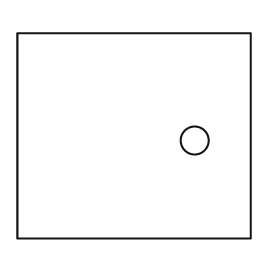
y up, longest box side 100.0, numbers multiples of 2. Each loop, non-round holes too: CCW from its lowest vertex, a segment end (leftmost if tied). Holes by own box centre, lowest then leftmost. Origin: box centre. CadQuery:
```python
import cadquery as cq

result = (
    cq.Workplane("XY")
    .moveTo(-50.0, -44.0)
    .lineTo(50.0, -44.0)
    .lineTo(50.0, 44.0)
    .lineTo(-50.0, 44.0)
    .close()
    .moveTo(26.0, -2.0)
    .circle(6.0)
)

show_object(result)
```